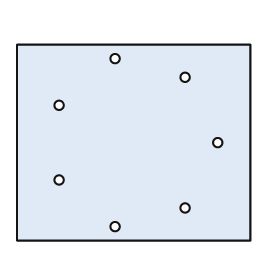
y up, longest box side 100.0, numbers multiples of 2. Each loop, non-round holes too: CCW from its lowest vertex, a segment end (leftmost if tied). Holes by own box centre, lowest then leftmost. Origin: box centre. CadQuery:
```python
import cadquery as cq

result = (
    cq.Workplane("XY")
    .moveTo(-50.0, -42.0)
    .lineTo(50.0, -42.0)
    .lineTo(50.0, 42.0)
    .lineTo(-50.0, 42.0)
    .close()
    .moveTo(-8.0, -36.0)
    .circle(2.0)
    .moveTo(22.0, -28.0)
    .circle(2.0)
    .moveTo(-32.0, -16.0)
    .circle(2.0)
    .moveTo(36.0, 0.0)
    .circle(2.0)
    .moveTo(-32.0, 16.0)
    .circle(2.0)
    .moveTo(22.0, 28.0)
    .circle(2.0)
    .moveTo(-8.0, 36.0)
    .circle(2.0)
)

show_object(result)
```